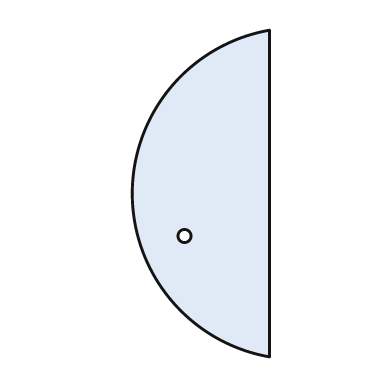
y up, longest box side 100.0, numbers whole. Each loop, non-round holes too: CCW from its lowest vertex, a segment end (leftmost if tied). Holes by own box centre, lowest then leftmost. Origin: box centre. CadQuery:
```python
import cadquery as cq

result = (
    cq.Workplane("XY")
    .moveTo(21.0, -50.0)
    .lineTo(21.0, 50.0)
    .threePointArc((-21.0, 0.0), (21.0, -50.0))
    .close()
    .moveTo(-5.0, -13.0)
    .circle(2.0)
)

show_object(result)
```